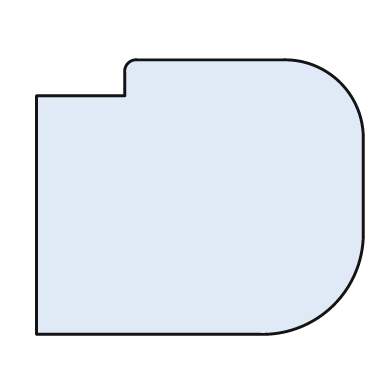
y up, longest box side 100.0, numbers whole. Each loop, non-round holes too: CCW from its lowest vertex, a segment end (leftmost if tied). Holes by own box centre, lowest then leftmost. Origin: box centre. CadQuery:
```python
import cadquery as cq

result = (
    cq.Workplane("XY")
    .moveTo(-50.0, -42.0)
    .lineTo(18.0, -42.0)
    .threePointArc((41.0, -33.0), (50.0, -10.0))
    .lineTo(50.0, 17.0)
    .threePointArc((43.0, 35.0), (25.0, 42.0))
    .lineTo(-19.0, 42.0)
    .threePointArc((-22.0, 41.0), (-23.0, 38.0))
    .lineTo(-23.0, 31.0)
    .lineTo(-50.0, 31.0)
    .close()
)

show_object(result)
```